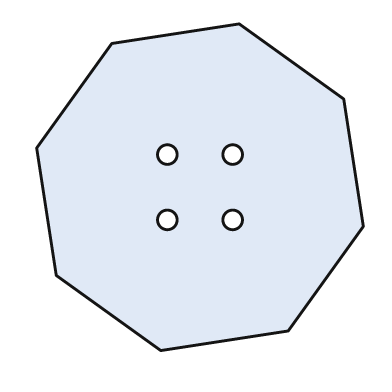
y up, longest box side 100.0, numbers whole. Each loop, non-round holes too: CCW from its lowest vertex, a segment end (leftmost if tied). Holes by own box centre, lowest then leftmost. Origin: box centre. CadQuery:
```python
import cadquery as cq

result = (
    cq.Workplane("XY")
    .moveTo(-12.0, -50.0)
    .lineTo(27.0, -44.0)
    .lineTo(50.0, -12.0)
    .lineTo(44.0, 27.0)
    .lineTo(12.0, 50.0)
    .lineTo(-27.0, 44.0)
    .lineTo(-50.0, 12.0)
    .lineTo(-44.0, -27.0)
    .close()
    .moveTo(-10.0, -10.0)
    .circle(3.0)
    .moveTo(10.0, -10.0)
    .circle(3.0)
    .moveTo(-10.0, 10.0)
    .circle(3.0)
    .moveTo(10.0, 10.0)
    .circle(3.0)
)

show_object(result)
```